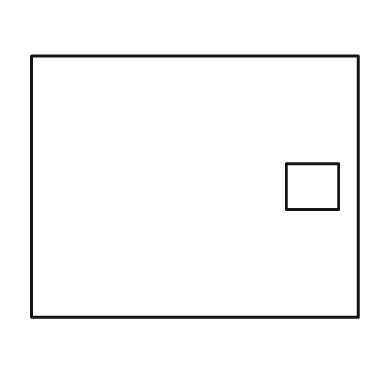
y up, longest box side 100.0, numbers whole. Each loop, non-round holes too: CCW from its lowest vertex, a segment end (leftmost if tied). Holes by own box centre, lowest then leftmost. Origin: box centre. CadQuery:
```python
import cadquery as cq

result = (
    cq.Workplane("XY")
    .moveTo(-50.0, -40.0)
    .lineTo(50.0, -40.0)
    .lineTo(50.0, 40.0)
    .lineTo(-50.0, 40.0)
    .close()
    .moveTo(28.0, -7.0)
    .lineTo(44.0, -7.0)
    .lineTo(44.0, 7.0)
    .lineTo(28.0, 7.0)
    .close()
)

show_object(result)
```